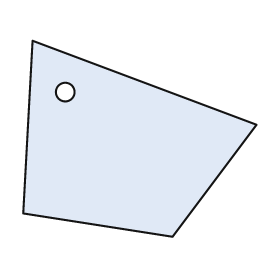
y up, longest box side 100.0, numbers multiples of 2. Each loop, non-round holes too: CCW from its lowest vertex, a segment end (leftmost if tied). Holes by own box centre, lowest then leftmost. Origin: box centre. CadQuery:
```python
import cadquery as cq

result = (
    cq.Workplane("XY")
    .moveTo(14.0, -42.0)
    .lineTo(50.0, 6.0)
    .lineTo(-46.0, 42.0)
    .lineTo(-50.0, -32.0)
    .close()
    .moveTo(-32.0, 20.0)
    .circle(4.0)
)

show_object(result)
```